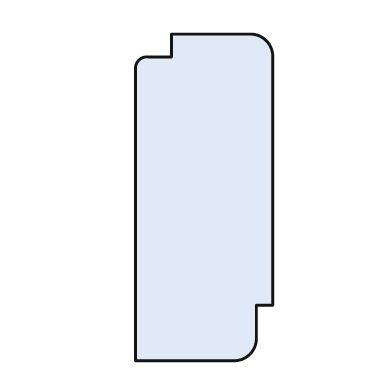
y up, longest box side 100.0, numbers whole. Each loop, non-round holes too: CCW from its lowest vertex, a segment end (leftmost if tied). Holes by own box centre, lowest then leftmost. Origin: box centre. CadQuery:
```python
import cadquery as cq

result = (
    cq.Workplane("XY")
    .moveTo(-21.0, -50.0)
    .lineTo(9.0, -50.0)
    .threePointArc((14.0, -48.0), (16.0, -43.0))
    .lineTo(16.0, -33.0)
    .lineTo(21.0, -33.0)
    .lineTo(21.0, 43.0)
    .threePointArc((19.0, 48.0), (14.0, 50.0))
    .lineTo(-10.0, 50.0)
    .lineTo(-10.0, 43.0)
    .lineTo(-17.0, 43.0)
    .threePointArc((-20.0, 42.0), (-21.0, 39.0))
    .close()
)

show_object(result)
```